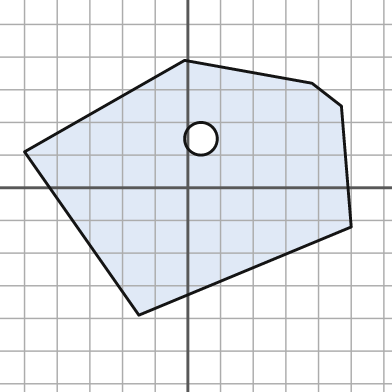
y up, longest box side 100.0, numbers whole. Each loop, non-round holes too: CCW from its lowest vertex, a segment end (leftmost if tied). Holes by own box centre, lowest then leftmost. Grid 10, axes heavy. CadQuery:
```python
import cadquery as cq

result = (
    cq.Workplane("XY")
    .moveTo(-15.0, -39.0)
    .lineTo(50.0, -12.0)
    .lineTo(47.0, 25.0)
    .lineTo(38.0, 32.0)
    .lineTo(-1.0, 39.0)
    .lineTo(-50.0, 11.0)
    .close()
    .moveTo(4.0, 15.0)
    .circle(5.0)
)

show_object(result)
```